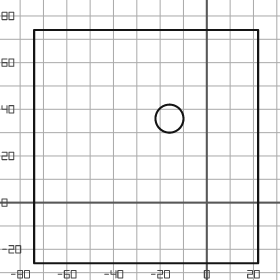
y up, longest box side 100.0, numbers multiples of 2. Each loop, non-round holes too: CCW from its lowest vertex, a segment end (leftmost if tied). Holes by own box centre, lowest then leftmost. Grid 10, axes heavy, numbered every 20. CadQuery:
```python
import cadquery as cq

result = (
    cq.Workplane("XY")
    .moveTo(-74.0, -26.0)
    .lineTo(22.0, -26.0)
    .lineTo(22.0, 74.0)
    .lineTo(-74.0, 74.0)
    .close()
    .moveTo(-16.0, 36.0)
    .circle(6.0)
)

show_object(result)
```